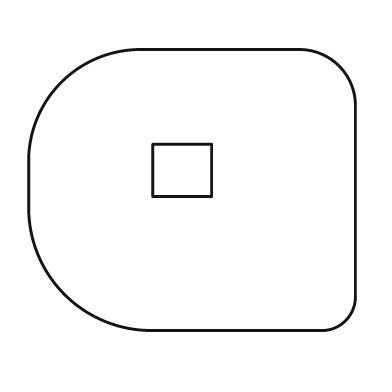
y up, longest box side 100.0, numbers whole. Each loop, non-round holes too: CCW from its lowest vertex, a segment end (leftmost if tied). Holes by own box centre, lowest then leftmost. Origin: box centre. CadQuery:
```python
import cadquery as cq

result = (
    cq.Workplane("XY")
    .moveTo(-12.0, -43.0)
    .lineTo(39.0, -43.0)
    .threePointArc((47.0, -40.0), (50.0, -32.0))
    .lineTo(50.0, 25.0)
    .threePointArc((45.0, 38.0), (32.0, 43.0))
    .lineTo(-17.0, 43.0)
    .threePointArc((-40.0, 33.0), (-50.0, 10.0))
    .lineTo(-50.0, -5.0)
    .threePointArc((-39.0, -32.0), (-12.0, -43.0))
    .close()
    .moveTo(-12.0, -2.0)
    .lineTo(6.0, -2.0)
    .lineTo(6.0, 14.0)
    .lineTo(-12.0, 14.0)
    .close()
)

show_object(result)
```